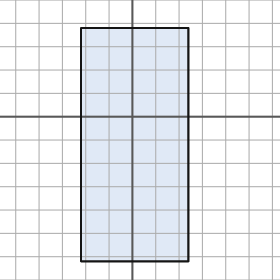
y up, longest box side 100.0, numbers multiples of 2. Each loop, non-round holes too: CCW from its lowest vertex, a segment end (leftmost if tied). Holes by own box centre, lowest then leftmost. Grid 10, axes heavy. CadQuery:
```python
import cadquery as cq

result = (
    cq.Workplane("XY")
    .moveTo(-22.0, -62.0)
    .lineTo(24.0, -62.0)
    .lineTo(24.0, 38.0)
    .lineTo(-22.0, 38.0)
    .close()
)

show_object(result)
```